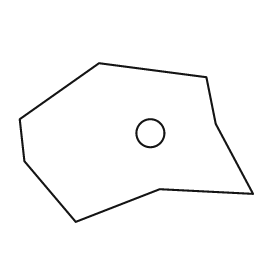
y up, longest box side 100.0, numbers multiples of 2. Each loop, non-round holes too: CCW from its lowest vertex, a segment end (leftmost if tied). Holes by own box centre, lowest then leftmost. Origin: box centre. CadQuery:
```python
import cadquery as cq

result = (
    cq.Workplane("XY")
    .moveTo(-26.0, -34.0)
    .lineTo(10.0, -20.0)
    .lineTo(50.0, -22.0)
    .lineTo(34.0, 8.0)
    .lineTo(30.0, 28.0)
    .lineTo(-16.0, 34.0)
    .lineTo(-50.0, 10.0)
    .lineTo(-48.0, -8.0)
    .close()
    .moveTo(6.0, 4.0)
    .circle(6.0)
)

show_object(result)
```